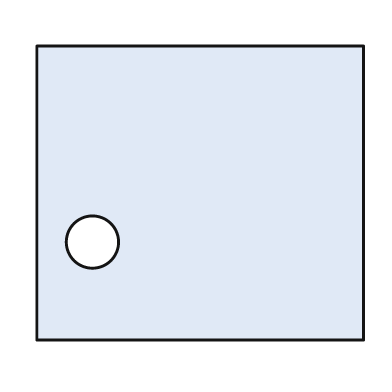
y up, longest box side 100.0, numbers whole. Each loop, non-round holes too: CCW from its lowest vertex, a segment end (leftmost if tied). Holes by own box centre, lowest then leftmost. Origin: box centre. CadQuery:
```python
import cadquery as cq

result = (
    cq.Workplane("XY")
    .moveTo(-50.0, -45.0)
    .lineTo(50.0, -45.0)
    .lineTo(50.0, 45.0)
    .lineTo(-50.0, 45.0)
    .close()
    .moveTo(-33.0, -15.0)
    .circle(8.0)
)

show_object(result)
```